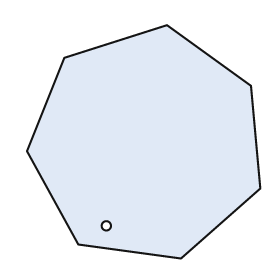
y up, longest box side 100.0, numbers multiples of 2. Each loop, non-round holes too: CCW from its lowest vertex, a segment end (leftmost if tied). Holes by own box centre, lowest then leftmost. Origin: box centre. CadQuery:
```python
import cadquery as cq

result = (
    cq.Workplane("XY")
    .moveTo(16.0, -50.0)
    .lineTo(50.0, -20.0)
    .lineTo(46.0, 24.0)
    .lineTo(10.0, 50.0)
    .lineTo(-34.0, 36.0)
    .lineTo(-50.0, -4.0)
    .lineTo(-28.0, -44.0)
    .close()
    .moveTo(-16.0, -36.0)
    .circle(2.0)
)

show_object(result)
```